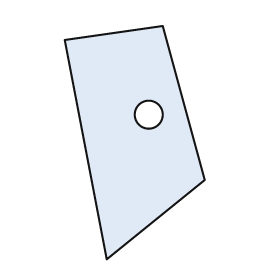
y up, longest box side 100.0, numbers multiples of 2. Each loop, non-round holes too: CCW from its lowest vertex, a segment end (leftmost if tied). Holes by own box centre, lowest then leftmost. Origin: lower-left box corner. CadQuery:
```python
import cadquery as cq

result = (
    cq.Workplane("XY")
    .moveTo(18.0, 0.0)
    .lineTo(60.0, 34.0)
    .lineTo(42.0, 100.0)
    .lineTo(0.0, 94.0)
    .close()
    .moveTo(36.0, 62.0)
    .circle(6.0)
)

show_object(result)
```